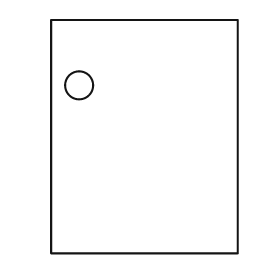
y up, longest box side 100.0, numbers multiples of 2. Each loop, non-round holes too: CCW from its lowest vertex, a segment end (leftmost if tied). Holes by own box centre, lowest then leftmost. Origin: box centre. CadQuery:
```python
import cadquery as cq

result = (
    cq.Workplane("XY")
    .moveTo(-40.0, -50.0)
    .lineTo(40.0, -50.0)
    .lineTo(40.0, 50.0)
    .lineTo(-40.0, 50.0)
    .close()
    .moveTo(-28.0, 22.0)
    .circle(6.0)
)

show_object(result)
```